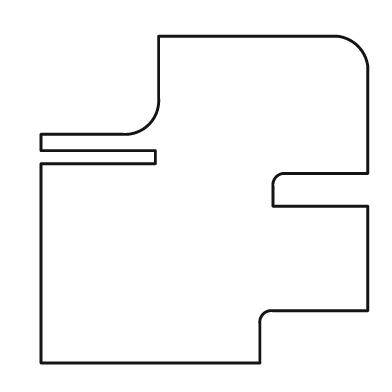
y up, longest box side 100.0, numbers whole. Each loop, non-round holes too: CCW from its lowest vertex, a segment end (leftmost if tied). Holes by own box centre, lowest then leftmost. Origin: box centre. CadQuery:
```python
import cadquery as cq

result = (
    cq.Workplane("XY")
    .moveTo(-50.0, -50.0)
    .lineTo(17.0, -50.0)
    .lineTo(17.0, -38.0)
    .threePointArc((18.0, -35.0), (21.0, -34.0))
    .lineTo(50.0, -34.0)
    .lineTo(50.0, -2.0)
    .lineTo(21.0, -2.0)
    .lineTo(21.0, 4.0)
    .threePointArc((22.0, 7.0), (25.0, 8.0))
    .lineTo(50.0, 8.0)
    .lineTo(50.0, 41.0)
    .threePointArc((47.0, 47.0), (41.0, 50.0))
    .lineTo(-14.0, 50.0)
    .lineTo(-14.0, 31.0)
    .threePointArc((-17.0, 23.0), (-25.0, 20.0))
    .lineTo(-50.0, 20.0)
    .lineTo(-50.0, 15.0)
    .lineTo(-15.0, 15.0)
    .lineTo(-15.0, 11.0)
    .lineTo(-50.0, 11.0)
    .close()
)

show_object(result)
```